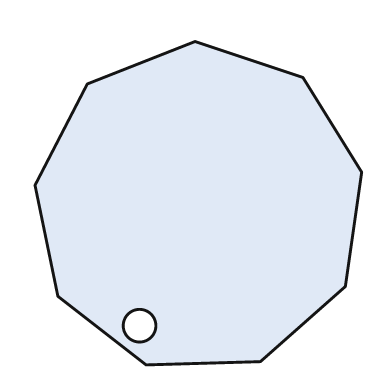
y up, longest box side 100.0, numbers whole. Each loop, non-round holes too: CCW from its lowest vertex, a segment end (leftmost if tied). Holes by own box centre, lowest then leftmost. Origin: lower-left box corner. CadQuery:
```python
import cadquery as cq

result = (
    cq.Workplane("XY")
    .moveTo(34.0, 0.0)
    .lineTo(69.0, 1.0)
    .lineTo(95.0, 24.0)
    .lineTo(100.0, 59.0)
    .lineTo(82.0, 88.0)
    .lineTo(49.0, 99.0)
    .lineTo(16.0, 86.0)
    .lineTo(0.0, 55.0)
    .lineTo(7.0, 21.0)
    .close()
    .moveTo(32.0, 12.0)
    .circle(5.0)
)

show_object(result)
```